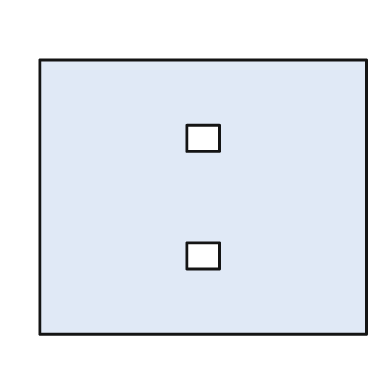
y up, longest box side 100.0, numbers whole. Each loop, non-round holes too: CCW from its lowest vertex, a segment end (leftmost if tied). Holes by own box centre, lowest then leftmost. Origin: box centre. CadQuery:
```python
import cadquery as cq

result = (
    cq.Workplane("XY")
    .moveTo(-50.0, -42.0)
    .lineTo(50.0, -42.0)
    .lineTo(50.0, 42.0)
    .lineTo(-50.0, 42.0)
    .close()
    .moveTo(-5.0, -22.0)
    .lineTo(5.0, -22.0)
    .lineTo(5.0, -14.0)
    .lineTo(-5.0, -14.0)
    .close()
    .moveTo(-5.0, 14.0)
    .lineTo(5.0, 14.0)
    .lineTo(5.0, 22.0)
    .lineTo(-5.0, 22.0)
    .close()
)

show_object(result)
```